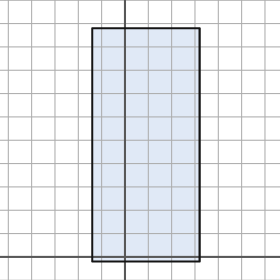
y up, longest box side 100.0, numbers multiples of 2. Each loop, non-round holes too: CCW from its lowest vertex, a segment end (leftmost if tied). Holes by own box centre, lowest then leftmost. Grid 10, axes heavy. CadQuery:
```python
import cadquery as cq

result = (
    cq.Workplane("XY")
    .moveTo(-14.0, -2.0)
    .lineTo(32.0, -2.0)
    .lineTo(32.0, 98.0)
    .lineTo(-14.0, 98.0)
    .close()
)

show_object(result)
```